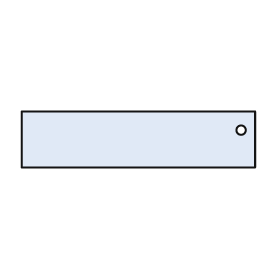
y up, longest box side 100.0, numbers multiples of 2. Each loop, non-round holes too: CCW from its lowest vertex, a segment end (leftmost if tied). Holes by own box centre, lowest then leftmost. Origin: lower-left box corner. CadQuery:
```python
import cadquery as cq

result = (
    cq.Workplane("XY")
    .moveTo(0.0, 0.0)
    .lineTo(100.0, 0.0)
    .lineTo(100.0, 24.0)
    .lineTo(0.0, 24.0)
    .close()
    .moveTo(94.0, 16.0)
    .circle(2.0)
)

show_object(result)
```